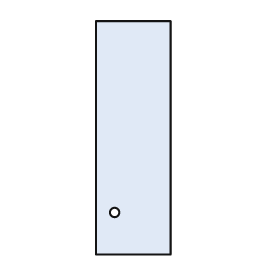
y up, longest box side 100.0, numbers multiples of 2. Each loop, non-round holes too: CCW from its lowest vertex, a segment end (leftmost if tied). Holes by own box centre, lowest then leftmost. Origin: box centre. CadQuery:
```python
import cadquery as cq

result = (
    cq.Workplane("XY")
    .moveTo(-16.0, -50.0)
    .lineTo(16.0, -50.0)
    .lineTo(16.0, 50.0)
    .lineTo(-16.0, 50.0)
    .close()
    .moveTo(-8.0, -32.0)
    .circle(2.0)
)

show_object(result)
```